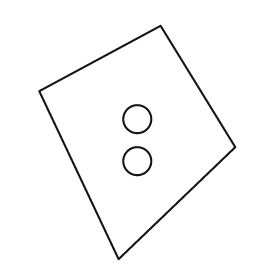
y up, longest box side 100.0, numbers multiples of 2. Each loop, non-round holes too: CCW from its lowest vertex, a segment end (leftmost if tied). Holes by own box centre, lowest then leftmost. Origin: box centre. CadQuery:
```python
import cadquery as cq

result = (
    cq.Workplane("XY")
    .moveTo(-8.0, -50.0)
    .lineTo(42.0, -2.0)
    .lineTo(10.0, 50.0)
    .lineTo(-42.0, 22.0)
    .close()
    .moveTo(0.0, -8.0)
    .circle(6.0)
    .moveTo(0.0, 10.0)
    .circle(6.0)
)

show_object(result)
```